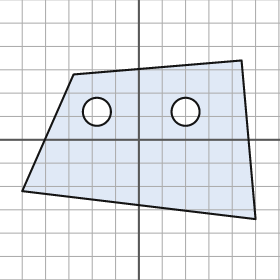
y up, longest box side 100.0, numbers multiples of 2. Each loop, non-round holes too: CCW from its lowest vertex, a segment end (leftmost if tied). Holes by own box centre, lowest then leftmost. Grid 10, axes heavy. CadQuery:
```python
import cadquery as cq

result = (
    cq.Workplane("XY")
    .moveTo(50.0, -34.0)
    .lineTo(44.0, 34.0)
    .lineTo(-28.0, 28.0)
    .lineTo(-50.0, -22.0)
    .close()
    .moveTo(-18.0, 12.0)
    .circle(6.0)
    .moveTo(20.0, 12.0)
    .circle(6.0)
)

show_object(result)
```